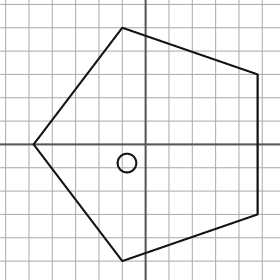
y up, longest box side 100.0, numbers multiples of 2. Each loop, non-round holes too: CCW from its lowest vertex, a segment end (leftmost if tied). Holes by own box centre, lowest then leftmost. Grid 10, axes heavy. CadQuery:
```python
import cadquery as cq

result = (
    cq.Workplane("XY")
    .moveTo(-10.0, -50.0)
    .lineTo(48.0, -30.0)
    .lineTo(48.0, 30.0)
    .lineTo(-10.0, 50.0)
    .lineTo(-48.0, 0.0)
    .close()
    .moveTo(-8.0, -8.0)
    .circle(4.0)
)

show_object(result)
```